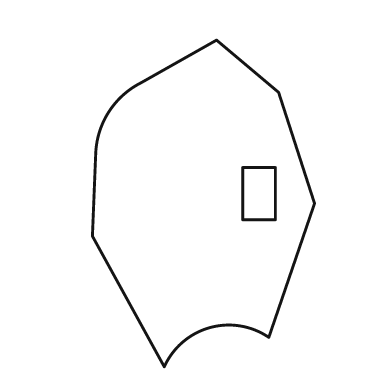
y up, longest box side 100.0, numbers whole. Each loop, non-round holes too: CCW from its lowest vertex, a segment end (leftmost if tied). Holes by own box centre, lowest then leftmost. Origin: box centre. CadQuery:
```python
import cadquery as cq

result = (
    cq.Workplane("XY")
    .moveTo(-12.0, -50.0)
    .threePointArc((2.0, -38.0), (20.0, -41.0))
    .lineTo(34.0, 0.0)
    .lineTo(23.0, 34.0)
    .lineTo(4.0, 50.0)
    .lineTo(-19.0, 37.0)
    .threePointArc((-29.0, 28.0), (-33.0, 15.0))
    .lineTo(-34.0, -10.0)
    .close()
    .moveTo(12.0, -5.0)
    .lineTo(22.0, -5.0)
    .lineTo(22.0, 11.0)
    .lineTo(12.0, 11.0)
    .close()
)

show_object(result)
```